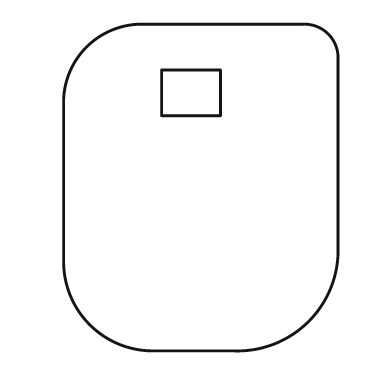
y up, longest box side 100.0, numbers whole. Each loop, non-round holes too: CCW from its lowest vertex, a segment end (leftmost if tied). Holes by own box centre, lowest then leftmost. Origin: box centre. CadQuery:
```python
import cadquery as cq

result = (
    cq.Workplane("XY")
    .moveTo(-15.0, -50.0)
    .lineTo(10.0, -50.0)
    .threePointArc((33.0, -41.0), (42.0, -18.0))
    .lineTo(42.0, 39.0)
    .threePointArc((39.0, 47.0), (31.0, 50.0))
    .lineTo(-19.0, 50.0)
    .threePointArc((-35.0, 43.0), (-42.0, 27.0))
    .lineTo(-42.0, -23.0)
    .threePointArc((-34.0, -42.0), (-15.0, -50.0))
    .close()
    .moveTo(-12.0, 22.0)
    .lineTo(6.0, 22.0)
    .lineTo(6.0, 36.0)
    .lineTo(-12.0, 36.0)
    .close()
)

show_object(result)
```